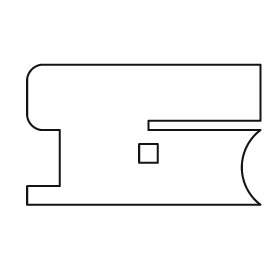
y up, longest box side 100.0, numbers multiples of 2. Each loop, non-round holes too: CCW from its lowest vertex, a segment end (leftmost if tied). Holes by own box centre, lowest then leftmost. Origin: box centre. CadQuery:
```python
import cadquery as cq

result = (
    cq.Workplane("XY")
    .moveTo(-50.0, -30.0)
    .lineTo(50.0, -30.0)
    .threePointArc((42.0, -14.0), (50.0, 2.0))
    .lineTo(2.0, 2.0)
    .lineTo(2.0, 6.0)
    .lineTo(50.0, 6.0)
    .lineTo(50.0, 30.0)
    .lineTo(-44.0, 30.0)
    .threePointArc((-48.0, 28.0), (-50.0, 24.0))
    .lineTo(-50.0, 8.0)
    .threePointArc((-48.0, 4.0), (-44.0, 2.0))
    .lineTo(-36.0, 2.0)
    .lineTo(-36.0, -22.0)
    .lineTo(-50.0, -22.0)
    .close()
    .moveTo(-2.0, -12.0)
    .lineTo(6.0, -12.0)
    .lineTo(6.0, -4.0)
    .lineTo(-2.0, -4.0)
    .close()
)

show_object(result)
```